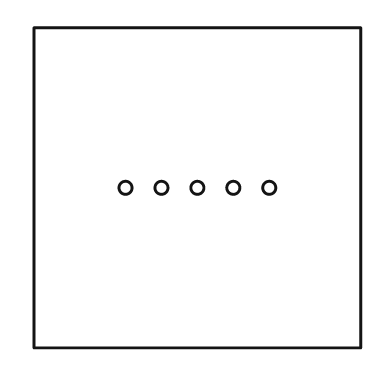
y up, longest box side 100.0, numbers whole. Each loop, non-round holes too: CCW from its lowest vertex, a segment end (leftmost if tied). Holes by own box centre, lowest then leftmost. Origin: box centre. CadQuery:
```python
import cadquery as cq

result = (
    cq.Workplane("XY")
    .moveTo(-50.0, -49.0)
    .lineTo(50.0, -49.0)
    .lineTo(50.0, 49.0)
    .lineTo(-50.0, 49.0)
    .close()
    .moveTo(-22.0, 0.0)
    .circle(2.0)
    .moveTo(-11.0, 0.0)
    .circle(2.0)
    .moveTo(0.0, 0.0)
    .circle(2.0)
    .moveTo(11.0, 0.0)
    .circle(2.0)
    .moveTo(22.0, 0.0)
    .circle(2.0)
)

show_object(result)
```